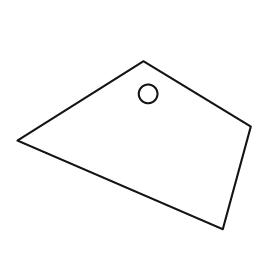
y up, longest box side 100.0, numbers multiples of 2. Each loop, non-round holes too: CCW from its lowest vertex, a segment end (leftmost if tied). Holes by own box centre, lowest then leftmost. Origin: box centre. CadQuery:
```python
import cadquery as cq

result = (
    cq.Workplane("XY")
    .moveTo(38.0, -36.0)
    .lineTo(50.0, 8.0)
    .lineTo(4.0, 36.0)
    .lineTo(-50.0, 2.0)
    .close()
    .moveTo(6.0, 22.0)
    .circle(4.0)
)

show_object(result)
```